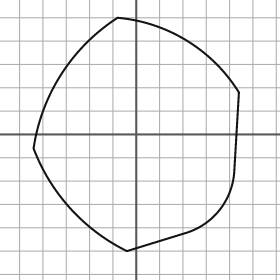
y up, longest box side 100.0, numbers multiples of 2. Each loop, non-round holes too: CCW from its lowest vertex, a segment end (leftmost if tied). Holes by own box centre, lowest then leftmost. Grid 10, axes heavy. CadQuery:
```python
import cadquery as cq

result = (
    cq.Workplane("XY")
    .moveTo(-4.0, -50.0)
    .lineTo(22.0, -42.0)
    .threePointArc((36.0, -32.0), (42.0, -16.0))
    .lineTo(44.0, 18.0)
    .threePointArc((22.0, 40.0), (-8.0, 50.0))
    .threePointArc((-32.0, 26.0), (-44.0, -6.0))
    .threePointArc((-28.0, -32.0), (-4.0, -50.0))
    .close()
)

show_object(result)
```